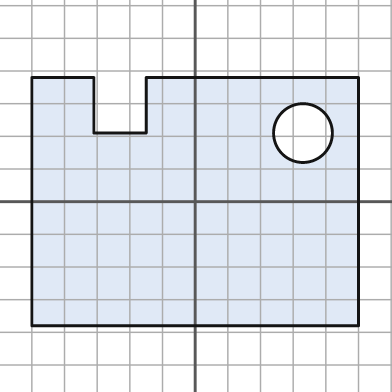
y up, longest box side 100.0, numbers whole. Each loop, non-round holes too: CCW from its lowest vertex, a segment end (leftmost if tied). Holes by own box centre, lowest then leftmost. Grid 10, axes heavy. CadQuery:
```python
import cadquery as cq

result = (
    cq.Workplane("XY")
    .moveTo(-50.0, -38.0)
    .lineTo(50.0, -38.0)
    .lineTo(50.0, 38.0)
    .lineTo(-15.0, 38.0)
    .lineTo(-15.0, 21.0)
    .lineTo(-31.0, 21.0)
    .lineTo(-31.0, 38.0)
    .lineTo(-50.0, 38.0)
    .close()
    .moveTo(33.0, 21.0)
    .circle(9.0)
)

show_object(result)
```